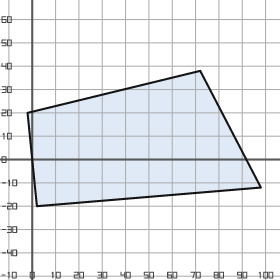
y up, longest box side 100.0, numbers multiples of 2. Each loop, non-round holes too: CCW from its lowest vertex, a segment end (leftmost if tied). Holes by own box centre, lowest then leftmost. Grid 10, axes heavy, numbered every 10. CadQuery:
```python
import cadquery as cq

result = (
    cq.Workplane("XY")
    .moveTo(2.0, -20.0)
    .lineTo(98.0, -12.0)
    .lineTo(72.0, 38.0)
    .lineTo(-2.0, 20.0)
    .close()
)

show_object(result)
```